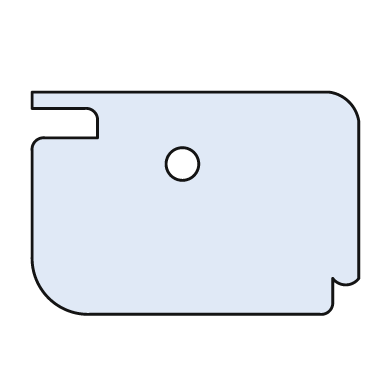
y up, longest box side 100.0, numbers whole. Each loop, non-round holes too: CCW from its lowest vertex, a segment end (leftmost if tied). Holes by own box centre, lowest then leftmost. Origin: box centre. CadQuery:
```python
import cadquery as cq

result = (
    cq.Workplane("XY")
    .moveTo(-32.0, -34.0)
    .lineTo(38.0, -34.0)
    .threePointArc((41.0, -33.0), (42.0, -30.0))
    .lineTo(42.0, -23.0)
    .threePointArc((46.0, -25.0), (50.0, -23.0))
    .lineTo(50.0, 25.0)
    .threePointArc((47.0, 31.0), (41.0, 34.0))
    .lineTo(-50.0, 34.0)
    .lineTo(-50.0, 29.0)
    .lineTo(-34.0, 29.0)
    .threePointArc((-31.0, 28.0), (-30.0, 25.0))
    .lineTo(-30.0, 20.0)
    .lineTo(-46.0, 20.0)
    .threePointArc((-49.0, 19.0), (-50.0, 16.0))
    .lineTo(-50.0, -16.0)
    .threePointArc((-45.0, -29.0), (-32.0, -34.0))
    .close()
    .moveTo(-4.0, 12.0)
    .circle(5.0)
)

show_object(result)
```